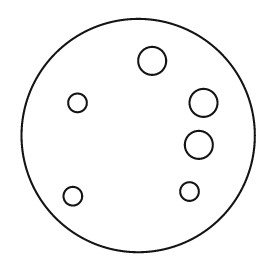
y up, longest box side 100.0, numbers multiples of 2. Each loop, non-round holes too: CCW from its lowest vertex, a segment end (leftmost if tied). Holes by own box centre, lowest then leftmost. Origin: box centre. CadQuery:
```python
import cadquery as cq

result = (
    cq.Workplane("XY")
    .moveTo(0.0, 0.0)
    .circle(50.0)
    .moveTo(-28.0, -26.0)
    .circle(4.0)
    .moveTo(22.0, -24.0)
    .circle(4.0)
    .moveTo(26.0, -4.0)
    .circle(6.0)
    .moveTo(-26.0, 14.0)
    .circle(4.0)
    .moveTo(28.0, 14.0)
    .circle(6.0)
    .moveTo(6.0, 32.0)
    .circle(6.0)
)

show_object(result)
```